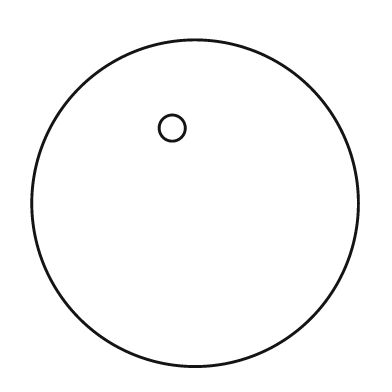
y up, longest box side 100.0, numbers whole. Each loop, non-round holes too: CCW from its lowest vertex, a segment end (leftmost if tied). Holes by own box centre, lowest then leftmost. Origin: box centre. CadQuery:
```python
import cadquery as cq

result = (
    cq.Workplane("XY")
    .moveTo(0.0, 0.0)
    .circle(50.0)
    .moveTo(-7.0, 23.0)
    .circle(4.0)
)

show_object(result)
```